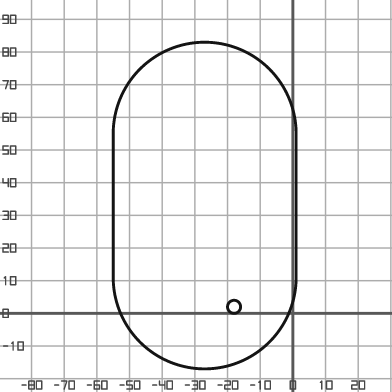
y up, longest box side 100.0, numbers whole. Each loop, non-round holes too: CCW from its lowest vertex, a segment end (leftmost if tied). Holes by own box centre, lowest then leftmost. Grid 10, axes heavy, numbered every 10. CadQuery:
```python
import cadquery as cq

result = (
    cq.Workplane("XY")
    .moveTo(-55.0, 11.0)
    .threePointArc((-27.0, -17.0), (1.0, 11.0))
    .lineTo(1.0, 55.0)
    .threePointArc((-27.0, 83.0), (-55.0, 55.0))
    .close()
    .moveTo(-18.0, 2.0)
    .circle(2.0)
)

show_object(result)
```